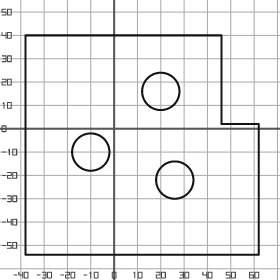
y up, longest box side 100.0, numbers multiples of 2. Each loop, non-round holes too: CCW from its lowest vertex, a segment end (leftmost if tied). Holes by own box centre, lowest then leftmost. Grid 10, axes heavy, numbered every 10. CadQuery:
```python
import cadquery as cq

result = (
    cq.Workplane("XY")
    .moveTo(-38.0, -54.0)
    .lineTo(62.0, -54.0)
    .lineTo(62.0, 2.0)
    .lineTo(46.0, 2.0)
    .lineTo(46.0, 40.0)
    .lineTo(-38.0, 40.0)
    .close()
    .moveTo(26.0, -22.0)
    .circle(8.0)
    .moveTo(-10.0, -10.0)
    .circle(8.0)
    .moveTo(20.0, 16.0)
    .circle(8.0)
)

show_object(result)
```